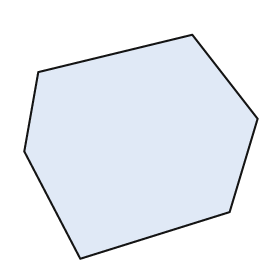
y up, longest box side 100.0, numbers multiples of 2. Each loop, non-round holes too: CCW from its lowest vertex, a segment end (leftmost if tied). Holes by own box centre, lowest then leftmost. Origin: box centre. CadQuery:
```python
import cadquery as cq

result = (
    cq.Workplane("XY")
    .moveTo(-26.0, -48.0)
    .lineTo(38.0, -28.0)
    .lineTo(50.0, 12.0)
    .lineTo(22.0, 48.0)
    .lineTo(-44.0, 32.0)
    .lineTo(-50.0, -2.0)
    .close()
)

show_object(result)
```